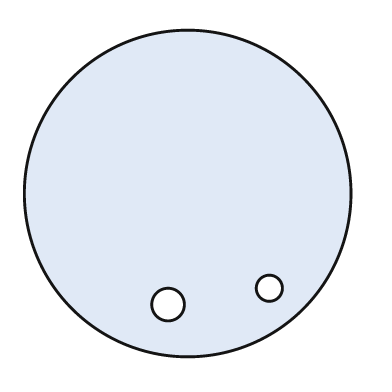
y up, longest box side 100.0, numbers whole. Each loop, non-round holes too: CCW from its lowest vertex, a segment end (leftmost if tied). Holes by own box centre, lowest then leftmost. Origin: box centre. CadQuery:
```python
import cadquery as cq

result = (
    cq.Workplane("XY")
    .moveTo(0.0, 0.0)
    .circle(50.0)
    .moveTo(-6.0, -34.0)
    .circle(5.0)
    .moveTo(25.0, -29.0)
    .circle(4.0)
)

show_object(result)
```